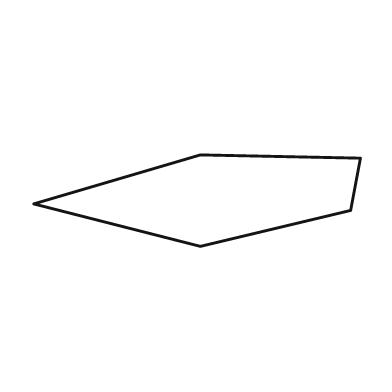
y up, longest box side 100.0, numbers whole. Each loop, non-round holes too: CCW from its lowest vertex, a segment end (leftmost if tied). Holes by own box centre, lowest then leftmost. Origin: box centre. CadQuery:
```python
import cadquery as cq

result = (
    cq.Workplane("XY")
    .moveTo(1.0, -14.0)
    .lineTo(47.0, -3.0)
    .lineTo(50.0, 13.0)
    .lineTo(1.0, 14.0)
    .lineTo(-50.0, -1.0)
    .close()
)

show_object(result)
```